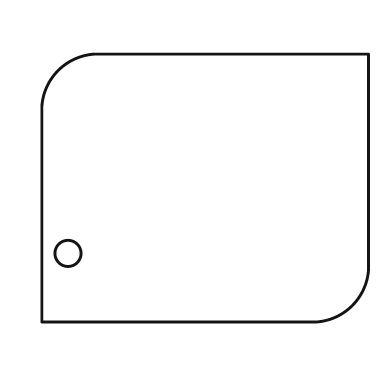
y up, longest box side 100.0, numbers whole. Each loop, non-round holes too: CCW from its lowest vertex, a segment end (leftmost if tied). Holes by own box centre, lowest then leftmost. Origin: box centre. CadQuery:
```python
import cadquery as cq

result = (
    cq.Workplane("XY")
    .moveTo(-50.0, -41.0)
    .lineTo(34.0, -41.0)
    .threePointArc((45.0, -36.0), (50.0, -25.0))
    .lineTo(50.0, 41.0)
    .lineTo(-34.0, 41.0)
    .threePointArc((-45.0, 36.0), (-50.0, 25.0))
    .close()
    .moveTo(-42.0, -20.0)
    .circle(4.0)
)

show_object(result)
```